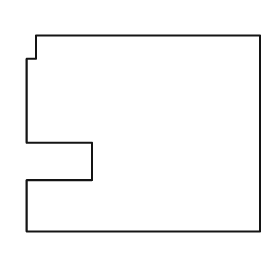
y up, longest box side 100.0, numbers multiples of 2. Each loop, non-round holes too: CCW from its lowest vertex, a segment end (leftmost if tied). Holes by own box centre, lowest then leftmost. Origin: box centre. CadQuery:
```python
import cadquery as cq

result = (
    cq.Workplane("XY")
    .moveTo(-50.0, -42.0)
    .lineTo(50.0, -42.0)
    .lineTo(50.0, 42.0)
    .lineTo(-46.0, 42.0)
    .lineTo(-46.0, 32.0)
    .lineTo(-50.0, 32.0)
    .lineTo(-50.0, -4.0)
    .lineTo(-22.0, -4.0)
    .lineTo(-22.0, -20.0)
    .lineTo(-50.0, -20.0)
    .close()
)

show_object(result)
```